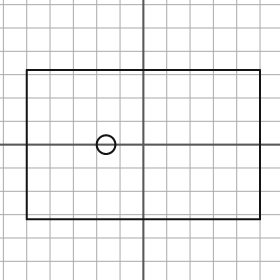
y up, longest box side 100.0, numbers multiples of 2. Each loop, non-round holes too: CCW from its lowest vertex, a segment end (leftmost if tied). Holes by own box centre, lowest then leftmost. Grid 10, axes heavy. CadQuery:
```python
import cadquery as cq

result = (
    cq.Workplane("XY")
    .moveTo(-50.0, -32.0)
    .lineTo(50.0, -32.0)
    .lineTo(50.0, 32.0)
    .lineTo(-50.0, 32.0)
    .close()
    .moveTo(-16.0, 0.0)
    .circle(4.0)
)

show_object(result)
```